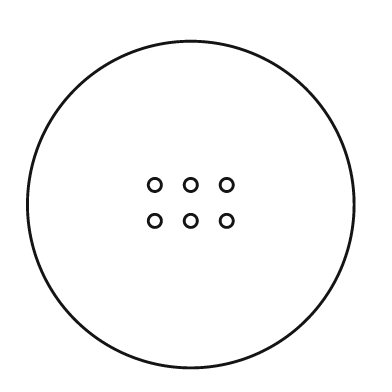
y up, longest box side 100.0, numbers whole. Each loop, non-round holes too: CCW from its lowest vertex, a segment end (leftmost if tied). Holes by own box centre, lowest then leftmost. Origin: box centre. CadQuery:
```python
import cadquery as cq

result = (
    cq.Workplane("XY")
    .moveTo(0.0, 0.0)
    .circle(50.0)
    .moveTo(-11.0, -5.0)
    .circle(2.0)
    .moveTo(0.0, -5.0)
    .circle(2.0)
    .moveTo(11.0, -5.0)
    .circle(2.0)
    .moveTo(-11.0, 6.0)
    .circle(2.0)
    .moveTo(0.0, 6.0)
    .circle(2.0)
    .moveTo(11.0, 6.0)
    .circle(2.0)
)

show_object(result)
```